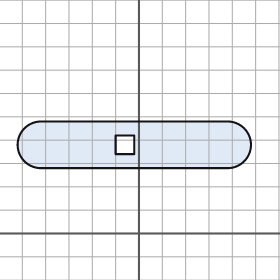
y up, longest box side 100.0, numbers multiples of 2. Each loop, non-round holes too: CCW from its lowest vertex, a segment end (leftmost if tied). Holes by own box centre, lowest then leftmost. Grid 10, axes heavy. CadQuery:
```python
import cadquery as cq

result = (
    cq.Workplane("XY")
    .moveTo(-42.0, 28.0)
    .lineTo(38.0, 28.0)
    .threePointArc((48.0, 38.0), (38.0, 48.0))
    .lineTo(-42.0, 48.0)
    .threePointArc((-52.0, 38.0), (-42.0, 28.0))
    .close()
    .moveTo(-10.0, 34.0)
    .lineTo(-2.0, 34.0)
    .lineTo(-2.0, 42.0)
    .lineTo(-10.0, 42.0)
    .close()
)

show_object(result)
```